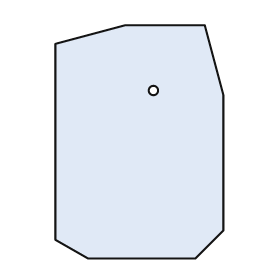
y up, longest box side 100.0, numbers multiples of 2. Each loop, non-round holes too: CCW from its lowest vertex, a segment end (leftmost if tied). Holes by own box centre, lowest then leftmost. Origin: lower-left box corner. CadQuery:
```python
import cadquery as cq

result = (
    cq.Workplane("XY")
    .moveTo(14.0, 0.0)
    .lineTo(60.0, 0.0)
    .lineTo(72.0, 12.0)
    .lineTo(72.0, 70.0)
    .lineTo(64.0, 100.0)
    .lineTo(30.0, 100.0)
    .lineTo(0.0, 92.0)
    .lineTo(0.0, 8.0)
    .close()
    .moveTo(42.0, 72.0)
    .circle(2.0)
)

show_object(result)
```